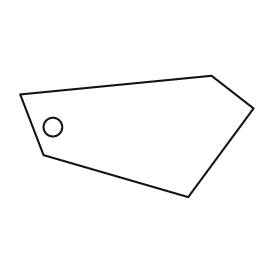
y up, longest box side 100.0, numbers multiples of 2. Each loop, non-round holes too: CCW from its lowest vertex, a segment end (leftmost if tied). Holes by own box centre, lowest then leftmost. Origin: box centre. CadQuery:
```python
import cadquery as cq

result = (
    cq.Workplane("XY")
    .moveTo(22.0, -26.0)
    .lineTo(50.0, 12.0)
    .lineTo(32.0, 26.0)
    .lineTo(-50.0, 18.0)
    .lineTo(-40.0, -8.0)
    .close()
    .moveTo(-36.0, 4.0)
    .circle(4.0)
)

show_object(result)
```